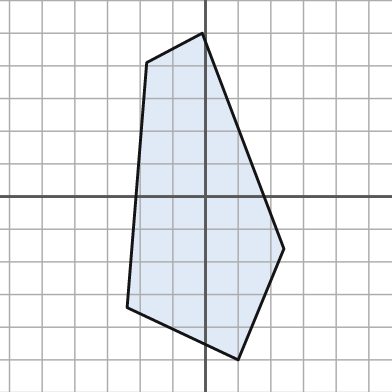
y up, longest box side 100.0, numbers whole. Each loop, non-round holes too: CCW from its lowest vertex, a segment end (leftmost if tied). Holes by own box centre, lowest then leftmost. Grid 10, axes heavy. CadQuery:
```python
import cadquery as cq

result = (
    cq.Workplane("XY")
    .moveTo(10.0, -50.0)
    .lineTo(24.0, -16.0)
    .lineTo(-1.0, 50.0)
    .lineTo(-18.0, 41.0)
    .lineTo(-24.0, -34.0)
    .close()
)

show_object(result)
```